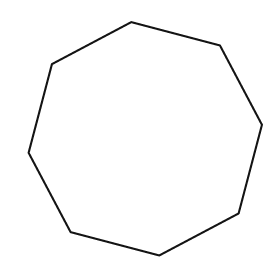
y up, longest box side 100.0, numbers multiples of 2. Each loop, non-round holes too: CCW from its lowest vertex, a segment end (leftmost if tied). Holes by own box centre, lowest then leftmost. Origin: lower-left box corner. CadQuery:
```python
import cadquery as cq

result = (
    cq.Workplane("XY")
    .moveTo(56.0, 0.0)
    .lineTo(90.0, 18.0)
    .lineTo(100.0, 56.0)
    .lineTo(82.0, 90.0)
    .lineTo(44.0, 100.0)
    .lineTo(10.0, 82.0)
    .lineTo(0.0, 44.0)
    .lineTo(18.0, 10.0)
    .close()
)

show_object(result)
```